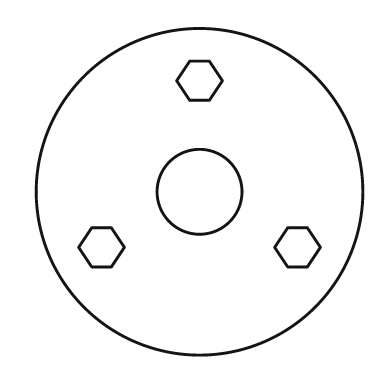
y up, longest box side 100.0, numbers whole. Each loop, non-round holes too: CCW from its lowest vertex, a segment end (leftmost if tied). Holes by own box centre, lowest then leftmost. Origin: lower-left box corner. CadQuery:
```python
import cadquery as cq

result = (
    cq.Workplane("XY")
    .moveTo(50.0, 50.0)
    .circle(50.0)
    .moveTo(17.0, 27.0)
    .lineTo(23.0, 27.0)
    .lineTo(27.0, 33.0)
    .lineTo(23.0, 39.0)
    .lineTo(17.0, 39.0)
    .lineTo(13.0, 33.0)
    .close()
    .moveTo(77.0, 27.0)
    .lineTo(83.0, 27.0)
    .lineTo(87.0, 33.0)
    .lineTo(83.0, 39.0)
    .lineTo(77.0, 39.0)
    .lineTo(73.0, 33.0)
    .close()
    .moveTo(50.0, 50.0)
    .circle(13.0)
    .moveTo(47.0, 78.0)
    .lineTo(53.0, 78.0)
    .lineTo(57.0, 84.0)
    .lineTo(53.0, 90.0)
    .lineTo(47.0, 90.0)
    .lineTo(43.0, 84.0)
    .close()
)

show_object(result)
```